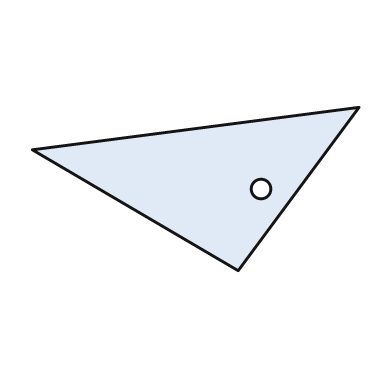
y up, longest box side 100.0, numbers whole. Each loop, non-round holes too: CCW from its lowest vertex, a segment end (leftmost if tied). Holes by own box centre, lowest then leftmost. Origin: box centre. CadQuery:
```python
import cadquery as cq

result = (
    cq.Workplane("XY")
    .moveTo(13.0, -25.0)
    .lineTo(50.0, 25.0)
    .lineTo(-50.0, 12.0)
    .close()
    .moveTo(20.0, 0.0)
    .circle(3.0)
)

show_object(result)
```